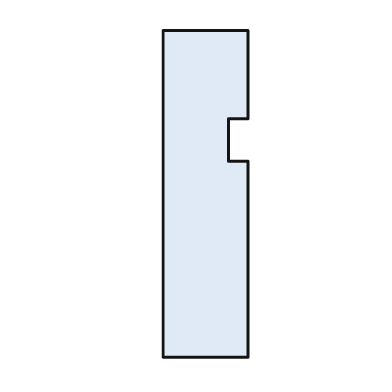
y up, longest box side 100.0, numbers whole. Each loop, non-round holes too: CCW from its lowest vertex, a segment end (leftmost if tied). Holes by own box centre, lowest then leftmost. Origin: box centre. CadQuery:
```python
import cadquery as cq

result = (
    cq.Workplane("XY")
    .moveTo(-13.0, -50.0)
    .lineTo(13.0, -50.0)
    .lineTo(13.0, 10.0)
    .lineTo(7.0, 10.0)
    .lineTo(7.0, 23.0)
    .lineTo(13.0, 23.0)
    .lineTo(13.0, 50.0)
    .lineTo(-13.0, 50.0)
    .close()
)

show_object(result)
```